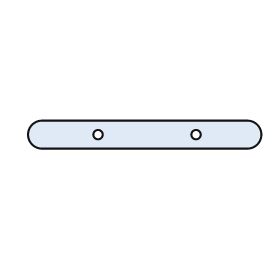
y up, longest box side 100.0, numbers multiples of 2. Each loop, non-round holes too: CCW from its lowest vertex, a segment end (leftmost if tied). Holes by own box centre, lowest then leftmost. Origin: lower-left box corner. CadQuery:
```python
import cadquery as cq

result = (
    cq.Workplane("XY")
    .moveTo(6.0, 0.0)
    .lineTo(94.0, 0.0)
    .threePointArc((100.0, 6.0), (94.0, 12.0))
    .lineTo(6.0, 12.0)
    .threePointArc((0.0, 6.0), (6.0, 0.0))
    .close()
    .moveTo(30.0, 6.0)
    .circle(2.0)
    .moveTo(72.0, 6.0)
    .circle(2.0)
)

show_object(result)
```